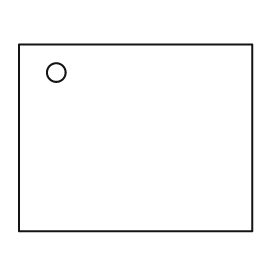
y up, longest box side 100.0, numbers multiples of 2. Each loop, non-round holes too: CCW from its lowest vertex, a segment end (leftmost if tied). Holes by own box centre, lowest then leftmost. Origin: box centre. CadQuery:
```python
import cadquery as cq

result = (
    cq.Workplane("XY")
    .moveTo(-50.0, -40.0)
    .lineTo(50.0, -40.0)
    .lineTo(50.0, 40.0)
    .lineTo(-50.0, 40.0)
    .close()
    .moveTo(-34.0, 28.0)
    .circle(4.0)
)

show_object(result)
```